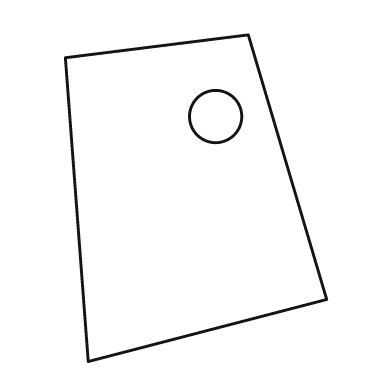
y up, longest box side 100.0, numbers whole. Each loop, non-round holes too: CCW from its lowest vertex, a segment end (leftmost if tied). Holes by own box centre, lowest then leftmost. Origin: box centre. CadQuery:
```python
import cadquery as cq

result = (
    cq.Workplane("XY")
    .moveTo(-33.0, -50.0)
    .lineTo(40.0, -31.0)
    .lineTo(16.0, 50.0)
    .lineTo(-40.0, 43.0)
    .close()
    .moveTo(6.0, 25.0)
    .circle(8.0)
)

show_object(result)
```